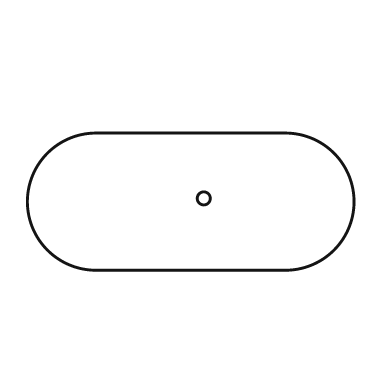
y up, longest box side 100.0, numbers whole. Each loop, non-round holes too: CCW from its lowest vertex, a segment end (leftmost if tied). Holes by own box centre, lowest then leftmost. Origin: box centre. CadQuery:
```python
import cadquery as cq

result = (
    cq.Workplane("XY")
    .moveTo(-29.0, -21.0)
    .lineTo(29.0, -21.0)
    .threePointArc((50.0, 0.0), (29.0, 21.0))
    .lineTo(-29.0, 21.0)
    .threePointArc((-50.0, 0.0), (-29.0, -21.0))
    .close()
    .moveTo(4.0, 1.0)
    .circle(2.0)
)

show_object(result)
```